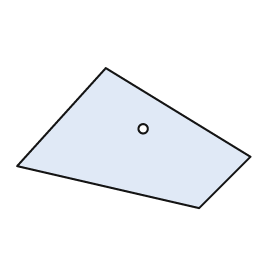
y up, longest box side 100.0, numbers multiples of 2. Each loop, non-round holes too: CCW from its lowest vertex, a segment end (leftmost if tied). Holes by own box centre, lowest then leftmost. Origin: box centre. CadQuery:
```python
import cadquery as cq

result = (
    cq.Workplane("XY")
    .moveTo(28.0, -30.0)
    .lineTo(50.0, -8.0)
    .lineTo(-12.0, 30.0)
    .lineTo(-50.0, -12.0)
    .close()
    .moveTo(4.0, 4.0)
    .circle(2.0)
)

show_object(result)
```